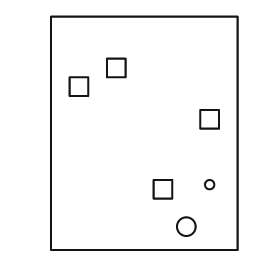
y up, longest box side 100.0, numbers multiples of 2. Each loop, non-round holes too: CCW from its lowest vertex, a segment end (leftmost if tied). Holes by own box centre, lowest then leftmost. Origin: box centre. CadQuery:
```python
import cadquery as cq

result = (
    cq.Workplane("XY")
    .moveTo(-40.0, -50.0)
    .lineTo(40.0, -50.0)
    .lineTo(40.0, 50.0)
    .lineTo(-40.0, 50.0)
    .close()
    .moveTo(18.0, -40.0)
    .circle(4.0)
    .moveTo(4.0, -28.0)
    .lineTo(12.0, -28.0)
    .lineTo(12.0, -20.0)
    .lineTo(4.0, -20.0)
    .close()
    .moveTo(28.0, -22.0)
    .circle(2.0)
    .moveTo(24.0, 2.0)
    .lineTo(32.0, 2.0)
    .lineTo(32.0, 10.0)
    .lineTo(24.0, 10.0)
    .close()
    .moveTo(-32.0, 16.0)
    .lineTo(-24.0, 16.0)
    .lineTo(-24.0, 24.0)
    .lineTo(-32.0, 24.0)
    .close()
    .moveTo(-16.0, 24.0)
    .lineTo(-8.0, 24.0)
    .lineTo(-8.0, 32.0)
    .lineTo(-16.0, 32.0)
    .close()
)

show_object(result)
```